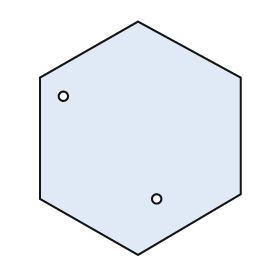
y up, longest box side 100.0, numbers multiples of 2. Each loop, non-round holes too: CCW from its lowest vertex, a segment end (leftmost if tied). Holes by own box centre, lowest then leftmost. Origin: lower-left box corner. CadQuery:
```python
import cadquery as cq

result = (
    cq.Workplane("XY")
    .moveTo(42.0, 0.0)
    .lineTo(86.0, 26.0)
    .lineTo(86.0, 76.0)
    .lineTo(42.0, 100.0)
    .lineTo(0.0, 76.0)
    .lineTo(0.0, 24.0)
    .close()
    .moveTo(50.0, 24.0)
    .circle(2.0)
    .moveTo(10.0, 68.0)
    .circle(2.0)
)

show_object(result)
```